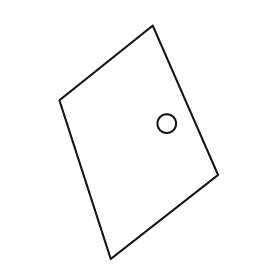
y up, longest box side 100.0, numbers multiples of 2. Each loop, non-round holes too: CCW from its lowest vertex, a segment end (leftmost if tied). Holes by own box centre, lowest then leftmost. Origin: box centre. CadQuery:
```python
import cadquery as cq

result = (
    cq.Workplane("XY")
    .moveTo(-12.0, -50.0)
    .lineTo(34.0, -14.0)
    .lineTo(6.0, 50.0)
    .lineTo(-34.0, 18.0)
    .close()
    .moveTo(12.0, 8.0)
    .circle(4.0)
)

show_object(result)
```